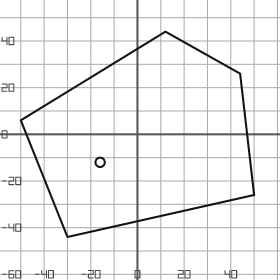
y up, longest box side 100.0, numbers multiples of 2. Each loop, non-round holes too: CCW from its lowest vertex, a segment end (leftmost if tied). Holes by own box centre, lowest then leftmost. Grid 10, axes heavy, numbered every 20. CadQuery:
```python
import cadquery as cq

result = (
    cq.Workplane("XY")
    .moveTo(-30.0, -44.0)
    .lineTo(50.0, -26.0)
    .lineTo(44.0, 26.0)
    .lineTo(12.0, 44.0)
    .lineTo(-50.0, 6.0)
    .close()
    .moveTo(-16.0, -12.0)
    .circle(2.0)
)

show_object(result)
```